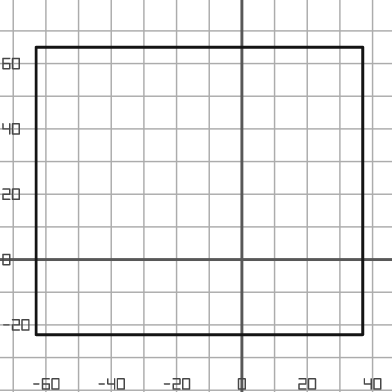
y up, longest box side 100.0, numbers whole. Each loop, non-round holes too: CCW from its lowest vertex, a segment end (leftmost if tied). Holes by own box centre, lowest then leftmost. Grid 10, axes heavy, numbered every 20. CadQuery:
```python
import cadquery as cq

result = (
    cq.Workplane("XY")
    .moveTo(-63.0, -23.0)
    .lineTo(37.0, -23.0)
    .lineTo(37.0, 65.0)
    .lineTo(-63.0, 65.0)
    .close()
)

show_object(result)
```